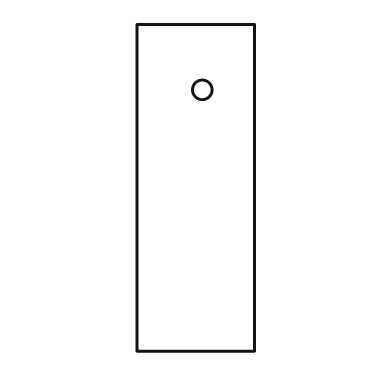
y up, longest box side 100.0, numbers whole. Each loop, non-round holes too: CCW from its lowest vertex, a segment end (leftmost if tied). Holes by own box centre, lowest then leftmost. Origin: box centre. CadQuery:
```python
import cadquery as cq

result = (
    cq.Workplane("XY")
    .moveTo(-18.0, -50.0)
    .lineTo(18.0, -50.0)
    .lineTo(18.0, 50.0)
    .lineTo(-18.0, 50.0)
    .close()
    .moveTo(2.0, 30.0)
    .circle(3.0)
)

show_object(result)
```